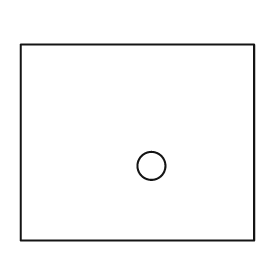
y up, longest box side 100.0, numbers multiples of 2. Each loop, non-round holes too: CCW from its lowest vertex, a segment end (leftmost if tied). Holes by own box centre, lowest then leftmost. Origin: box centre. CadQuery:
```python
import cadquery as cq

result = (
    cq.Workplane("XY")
    .moveTo(-50.0, -42.0)
    .lineTo(50.0, -42.0)
    .lineTo(50.0, 42.0)
    .lineTo(-50.0, 42.0)
    .close()
    .moveTo(6.0, -10.0)
    .circle(6.0)
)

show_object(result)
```